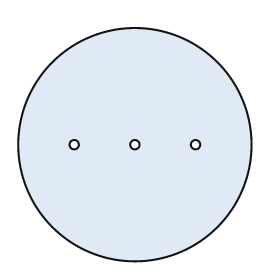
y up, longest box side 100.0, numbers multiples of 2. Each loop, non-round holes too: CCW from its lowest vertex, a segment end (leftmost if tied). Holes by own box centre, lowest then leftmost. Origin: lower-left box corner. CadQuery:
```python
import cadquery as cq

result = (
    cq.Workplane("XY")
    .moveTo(50.0, 50.0)
    .circle(50.0)
    .moveTo(24.0, 50.0)
    .circle(2.0)
    .moveTo(50.0, 50.0)
    .circle(2.0)
    .moveTo(76.0, 50.0)
    .circle(2.0)
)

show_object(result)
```